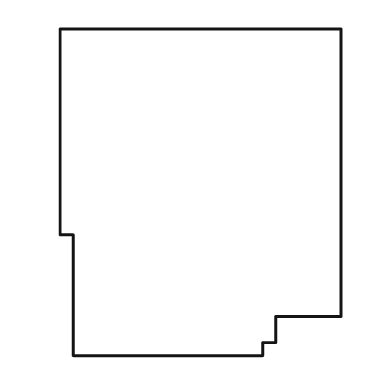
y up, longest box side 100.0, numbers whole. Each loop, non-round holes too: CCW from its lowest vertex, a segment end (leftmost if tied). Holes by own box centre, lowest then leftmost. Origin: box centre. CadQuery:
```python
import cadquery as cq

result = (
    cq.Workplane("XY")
    .moveTo(-39.0, -50.0)
    .lineTo(19.0, -50.0)
    .lineTo(19.0, -46.0)
    .lineTo(23.0, -46.0)
    .lineTo(23.0, -38.0)
    .lineTo(43.0, -38.0)
    .lineTo(43.0, 50.0)
    .lineTo(-43.0, 50.0)
    .lineTo(-43.0, -13.0)
    .lineTo(-39.0, -13.0)
    .close()
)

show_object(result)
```